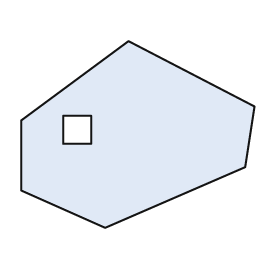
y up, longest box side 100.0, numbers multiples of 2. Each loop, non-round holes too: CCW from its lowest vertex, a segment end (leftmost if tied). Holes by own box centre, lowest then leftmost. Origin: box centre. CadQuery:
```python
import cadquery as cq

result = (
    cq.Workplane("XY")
    .moveTo(-14.0, -40.0)
    .lineTo(46.0, -14.0)
    .lineTo(50.0, 12.0)
    .lineTo(-4.0, 40.0)
    .lineTo(-50.0, 6.0)
    .lineTo(-50.0, -24.0)
    .close()
    .moveTo(-32.0, -4.0)
    .lineTo(-20.0, -4.0)
    .lineTo(-20.0, 8.0)
    .lineTo(-32.0, 8.0)
    .close()
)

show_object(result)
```